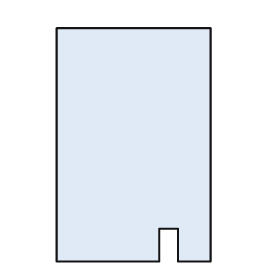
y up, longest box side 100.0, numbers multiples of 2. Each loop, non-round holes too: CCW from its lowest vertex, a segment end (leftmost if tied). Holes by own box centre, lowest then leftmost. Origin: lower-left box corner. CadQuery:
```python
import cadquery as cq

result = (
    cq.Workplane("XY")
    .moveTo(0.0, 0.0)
    .lineTo(44.0, 0.0)
    .lineTo(44.0, 14.0)
    .lineTo(52.0, 14.0)
    .lineTo(52.0, 0.0)
    .lineTo(66.0, 0.0)
    .lineTo(66.0, 100.0)
    .lineTo(0.0, 100.0)
    .close()
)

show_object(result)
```